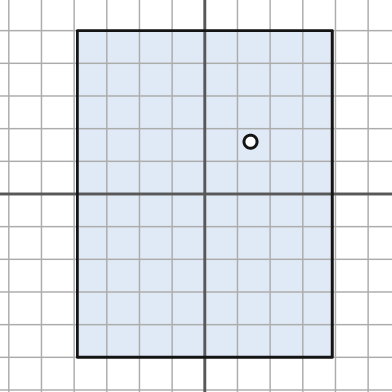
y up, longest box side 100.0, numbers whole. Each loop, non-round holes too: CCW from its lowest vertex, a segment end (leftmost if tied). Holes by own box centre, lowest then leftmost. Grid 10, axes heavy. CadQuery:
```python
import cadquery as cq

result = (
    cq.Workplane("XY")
    .moveTo(-39.0, -50.0)
    .lineTo(39.0, -50.0)
    .lineTo(39.0, 50.0)
    .lineTo(-39.0, 50.0)
    .close()
    .moveTo(14.0, 16.0)
    .circle(2.0)
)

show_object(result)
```